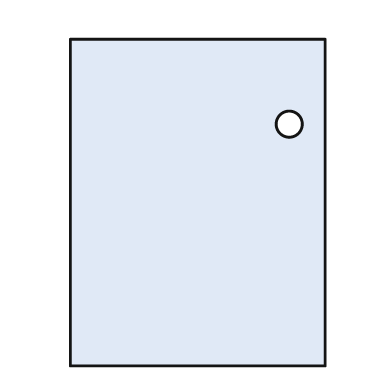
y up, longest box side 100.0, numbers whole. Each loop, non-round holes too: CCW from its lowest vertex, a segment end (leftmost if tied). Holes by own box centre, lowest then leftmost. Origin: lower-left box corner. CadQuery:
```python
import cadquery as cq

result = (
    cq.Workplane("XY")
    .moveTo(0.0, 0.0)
    .lineTo(78.0, 0.0)
    .lineTo(78.0, 100.0)
    .lineTo(0.0, 100.0)
    .close()
    .moveTo(67.0, 74.0)
    .circle(4.0)
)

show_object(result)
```